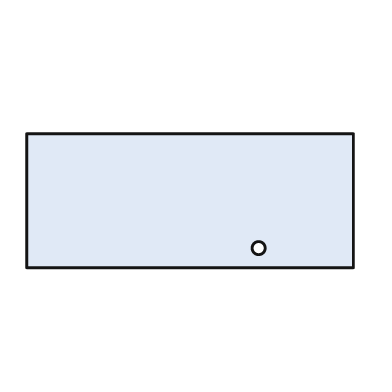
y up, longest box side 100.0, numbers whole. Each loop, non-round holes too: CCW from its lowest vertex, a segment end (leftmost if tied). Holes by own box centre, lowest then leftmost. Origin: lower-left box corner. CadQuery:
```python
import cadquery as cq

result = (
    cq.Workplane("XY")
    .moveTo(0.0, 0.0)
    .lineTo(100.0, 0.0)
    .lineTo(100.0, 41.0)
    .lineTo(0.0, 41.0)
    .close()
    .moveTo(71.0, 6.0)
    .circle(2.0)
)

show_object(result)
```